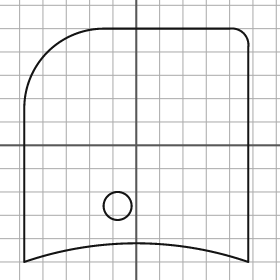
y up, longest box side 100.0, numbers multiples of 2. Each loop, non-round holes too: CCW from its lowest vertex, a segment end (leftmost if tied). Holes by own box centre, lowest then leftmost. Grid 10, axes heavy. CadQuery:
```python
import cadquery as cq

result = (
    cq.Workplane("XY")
    .moveTo(-48.0, -50.0)
    .threePointArc((0.0, -42.0), (48.0, -50.0))
    .lineTo(48.0, 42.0)
    .threePointArc((46.0, 48.0), (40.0, 50.0))
    .lineTo(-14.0, 50.0)
    .threePointArc((-38.0, 40.0), (-48.0, 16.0))
    .close()
    .moveTo(-8.0, -26.0)
    .circle(6.0)
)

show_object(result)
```